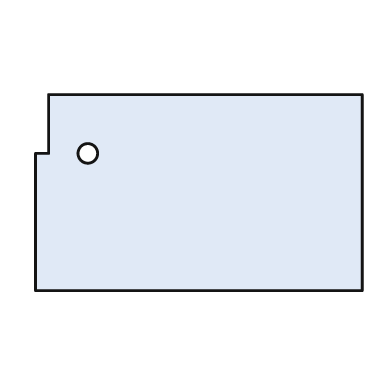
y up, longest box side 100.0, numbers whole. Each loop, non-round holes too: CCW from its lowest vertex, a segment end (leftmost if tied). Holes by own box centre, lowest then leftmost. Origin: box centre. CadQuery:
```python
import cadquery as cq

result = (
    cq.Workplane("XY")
    .moveTo(-50.0, -30.0)
    .lineTo(50.0, -30.0)
    .lineTo(50.0, 30.0)
    .lineTo(-46.0, 30.0)
    .lineTo(-46.0, 12.0)
    .lineTo(-50.0, 12.0)
    .close()
    .moveTo(-34.0, 12.0)
    .circle(3.0)
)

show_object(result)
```